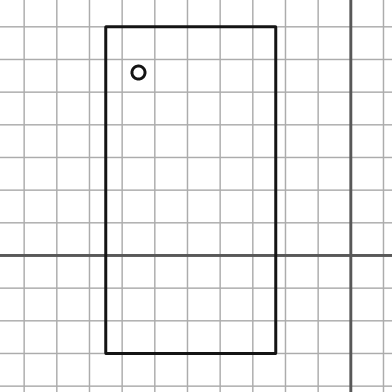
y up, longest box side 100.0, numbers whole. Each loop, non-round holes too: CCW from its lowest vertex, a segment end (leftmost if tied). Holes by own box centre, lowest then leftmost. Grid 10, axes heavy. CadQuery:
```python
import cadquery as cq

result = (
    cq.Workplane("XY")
    .moveTo(-75.0, -30.0)
    .lineTo(-23.0, -30.0)
    .lineTo(-23.0, 70.0)
    .lineTo(-75.0, 70.0)
    .close()
    .moveTo(-65.0, 56.0)
    .circle(2.0)
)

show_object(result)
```